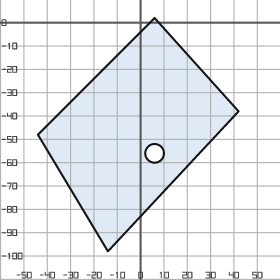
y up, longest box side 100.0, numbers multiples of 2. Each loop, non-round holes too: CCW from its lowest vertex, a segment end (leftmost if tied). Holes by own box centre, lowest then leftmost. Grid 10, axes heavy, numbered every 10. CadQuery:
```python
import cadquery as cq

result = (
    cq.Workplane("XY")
    .moveTo(-14.0, -98.0)
    .lineTo(42.0, -38.0)
    .lineTo(6.0, 2.0)
    .lineTo(-44.0, -48.0)
    .close()
    .moveTo(6.0, -56.0)
    .circle(4.0)
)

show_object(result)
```